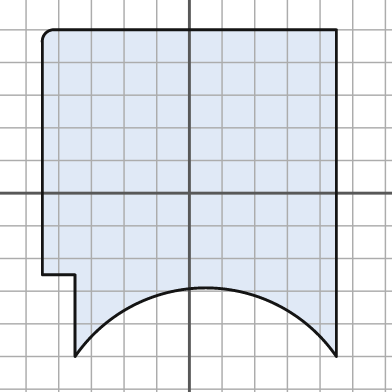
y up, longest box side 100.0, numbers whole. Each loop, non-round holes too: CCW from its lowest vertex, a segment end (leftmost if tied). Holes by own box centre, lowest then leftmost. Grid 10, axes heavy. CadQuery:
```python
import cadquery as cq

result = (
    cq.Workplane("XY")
    .moveTo(-35.0, -50.0)
    .threePointArc((5.0, -29.0), (45.0, -50.0))
    .lineTo(45.0, 50.0)
    .lineTo(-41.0, 50.0)
    .threePointArc((-44.0, 49.0), (-45.0, 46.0))
    .lineTo(-45.0, -25.0)
    .lineTo(-35.0, -25.0)
    .close()
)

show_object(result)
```